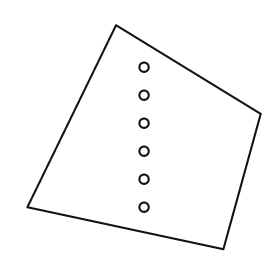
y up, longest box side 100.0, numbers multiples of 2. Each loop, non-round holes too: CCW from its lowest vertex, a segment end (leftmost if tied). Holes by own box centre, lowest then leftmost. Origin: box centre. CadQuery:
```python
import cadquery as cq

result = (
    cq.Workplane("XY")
    .moveTo(34.0, -48.0)
    .lineTo(50.0, 10.0)
    .lineTo(-12.0, 48.0)
    .lineTo(-50.0, -30.0)
    .close()
    .moveTo(0.0, -30.0)
    .circle(2.0)
    .moveTo(0.0, -18.0)
    .circle(2.0)
    .moveTo(0.0, -6.0)
    .circle(2.0)
    .moveTo(0.0, 6.0)
    .circle(2.0)
    .moveTo(0.0, 18.0)
    .circle(2.0)
    .moveTo(0.0, 30.0)
    .circle(2.0)
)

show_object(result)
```